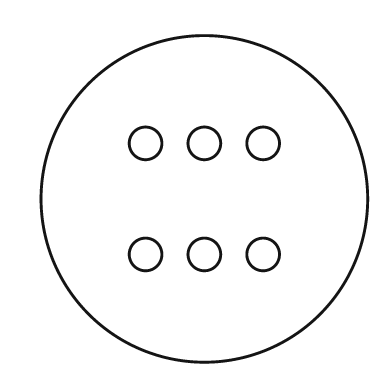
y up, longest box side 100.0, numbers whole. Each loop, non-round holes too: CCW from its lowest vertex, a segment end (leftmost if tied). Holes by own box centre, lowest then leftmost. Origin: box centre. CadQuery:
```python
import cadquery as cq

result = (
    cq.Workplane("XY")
    .moveTo(0.0, 0.0)
    .circle(50.0)
    .moveTo(-18.0, -17.0)
    .circle(5.0)
    .moveTo(0.0, -17.0)
    .circle(5.0)
    .moveTo(18.0, -17.0)
    .circle(5.0)
    .moveTo(-18.0, 17.0)
    .circle(5.0)
    .moveTo(0.0, 17.0)
    .circle(5.0)
    .moveTo(18.0, 17.0)
    .circle(5.0)
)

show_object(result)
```